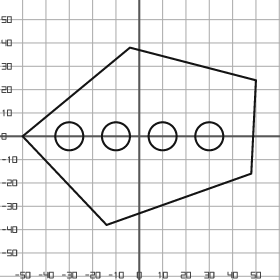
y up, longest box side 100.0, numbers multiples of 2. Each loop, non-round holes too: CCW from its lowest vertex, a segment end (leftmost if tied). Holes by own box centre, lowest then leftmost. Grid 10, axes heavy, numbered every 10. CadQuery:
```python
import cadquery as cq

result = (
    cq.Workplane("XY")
    .moveTo(-14.0, -38.0)
    .lineTo(48.0, -16.0)
    .lineTo(50.0, 24.0)
    .lineTo(-4.0, 38.0)
    .lineTo(-50.0, 0.0)
    .close()
    .moveTo(-30.0, 0.0)
    .circle(6.0)
    .moveTo(-10.0, 0.0)
    .circle(6.0)
    .moveTo(10.0, 0.0)
    .circle(6.0)
    .moveTo(30.0, 0.0)
    .circle(6.0)
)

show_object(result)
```